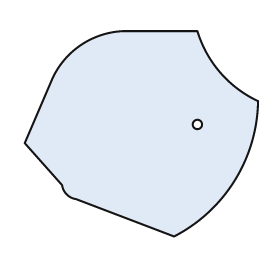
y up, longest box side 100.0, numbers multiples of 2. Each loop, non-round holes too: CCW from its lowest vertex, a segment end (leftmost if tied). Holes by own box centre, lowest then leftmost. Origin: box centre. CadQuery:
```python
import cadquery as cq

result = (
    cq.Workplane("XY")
    .moveTo(14.0, -44.0)
    .threePointArc((40.0, -20.0), (50.0, 14.0))
    .threePointArc((34.0, 26.0), (24.0, 44.0))
    .lineTo(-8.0, 44.0)
    .threePointArc((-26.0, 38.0), (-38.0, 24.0))
    .lineTo(-50.0, -4.0)
    .lineTo(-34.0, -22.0)
    .threePointArc((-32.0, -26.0), (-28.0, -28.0))
    .close()
    .moveTo(24.0, 4.0)
    .circle(2.0)
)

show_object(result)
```